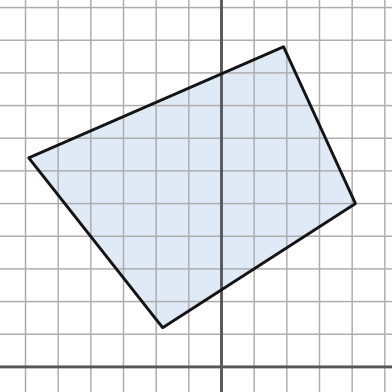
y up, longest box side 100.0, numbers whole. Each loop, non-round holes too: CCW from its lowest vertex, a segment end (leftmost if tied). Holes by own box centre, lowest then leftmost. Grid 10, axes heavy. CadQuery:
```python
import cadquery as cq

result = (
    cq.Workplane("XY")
    .moveTo(-18.0, 12.0)
    .lineTo(41.0, 50.0)
    .lineTo(19.0, 98.0)
    .lineTo(-59.0, 64.0)
    .close()
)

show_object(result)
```